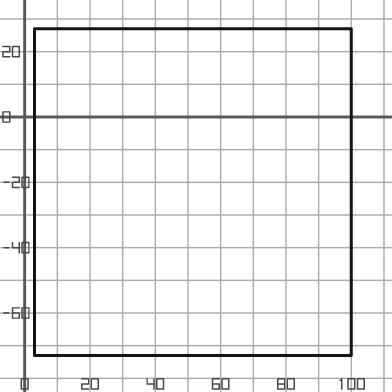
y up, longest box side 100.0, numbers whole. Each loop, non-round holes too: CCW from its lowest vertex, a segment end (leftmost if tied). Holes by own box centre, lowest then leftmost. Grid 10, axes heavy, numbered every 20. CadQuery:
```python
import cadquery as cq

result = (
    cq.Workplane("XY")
    .moveTo(3.0, -73.0)
    .lineTo(100.0, -73.0)
    .lineTo(100.0, 27.0)
    .lineTo(3.0, 27.0)
    .close()
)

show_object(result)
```